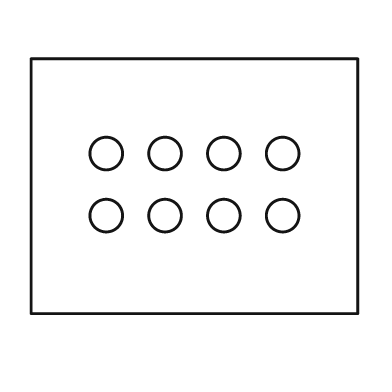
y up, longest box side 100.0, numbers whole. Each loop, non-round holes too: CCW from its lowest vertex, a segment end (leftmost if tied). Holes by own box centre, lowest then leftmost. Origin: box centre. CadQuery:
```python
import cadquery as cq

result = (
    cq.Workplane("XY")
    .moveTo(-50.0, -39.0)
    .lineTo(50.0, -39.0)
    .lineTo(50.0, 39.0)
    .lineTo(-50.0, 39.0)
    .close()
    .moveTo(-27.0, -9.0)
    .circle(5.0)
    .moveTo(-9.0, -9.0)
    .circle(5.0)
    .moveTo(9.0, -9.0)
    .circle(5.0)
    .moveTo(27.0, -9.0)
    .circle(5.0)
    .moveTo(-27.0, 10.0)
    .circle(5.0)
    .moveTo(-9.0, 10.0)
    .circle(5.0)
    .moveTo(9.0, 10.0)
    .circle(5.0)
    .moveTo(27.0, 10.0)
    .circle(5.0)
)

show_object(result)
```